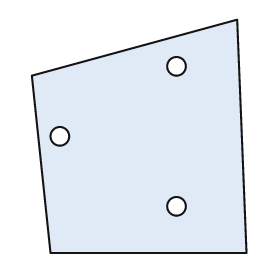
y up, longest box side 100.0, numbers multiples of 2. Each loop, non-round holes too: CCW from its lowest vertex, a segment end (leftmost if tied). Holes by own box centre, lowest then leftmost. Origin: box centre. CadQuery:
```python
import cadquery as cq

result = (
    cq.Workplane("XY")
    .moveTo(-38.0, -50.0)
    .lineTo(46.0, -50.0)
    .lineTo(42.0, 50.0)
    .lineTo(-46.0, 26.0)
    .close()
    .moveTo(16.0, -30.0)
    .circle(4.0)
    .moveTo(-34.0, 0.0)
    .circle(4.0)
    .moveTo(16.0, 30.0)
    .circle(4.0)
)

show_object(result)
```